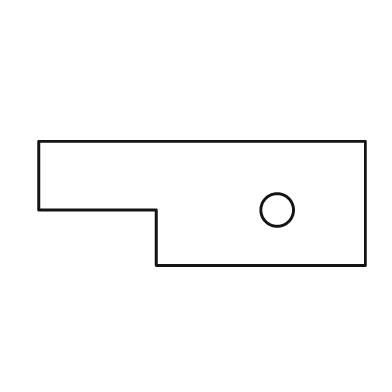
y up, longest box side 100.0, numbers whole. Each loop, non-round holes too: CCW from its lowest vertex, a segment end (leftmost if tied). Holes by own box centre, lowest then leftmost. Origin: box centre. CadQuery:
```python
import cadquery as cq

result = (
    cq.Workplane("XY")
    .moveTo(-14.0, -19.0)
    .lineTo(50.0, -19.0)
    .lineTo(50.0, 19.0)
    .lineTo(-50.0, 19.0)
    .lineTo(-50.0, -2.0)
    .lineTo(-14.0, -2.0)
    .close()
    .moveTo(23.0, -2.0)
    .circle(5.0)
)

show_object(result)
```